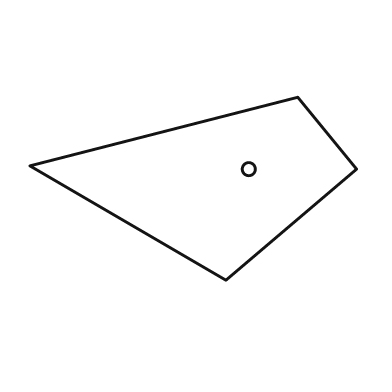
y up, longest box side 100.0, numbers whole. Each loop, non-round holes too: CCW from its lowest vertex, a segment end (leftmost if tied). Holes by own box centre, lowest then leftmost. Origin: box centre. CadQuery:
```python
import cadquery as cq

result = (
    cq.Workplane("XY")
    .moveTo(10.0, -28.0)
    .lineTo(50.0, 6.0)
    .lineTo(32.0, 28.0)
    .lineTo(-50.0, 7.0)
    .close()
    .moveTo(17.0, 6.0)
    .circle(2.0)
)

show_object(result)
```